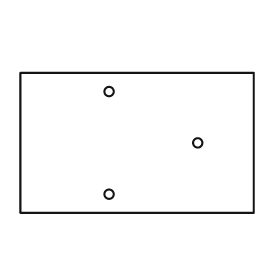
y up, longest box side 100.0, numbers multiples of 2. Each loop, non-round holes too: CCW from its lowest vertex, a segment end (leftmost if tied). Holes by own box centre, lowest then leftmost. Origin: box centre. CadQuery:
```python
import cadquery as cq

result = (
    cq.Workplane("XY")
    .moveTo(-50.0, -30.0)
    .lineTo(50.0, -30.0)
    .lineTo(50.0, 30.0)
    .lineTo(-50.0, 30.0)
    .close()
    .moveTo(-12.0, -22.0)
    .circle(2.0)
    .moveTo(26.0, 0.0)
    .circle(2.0)
    .moveTo(-12.0, 22.0)
    .circle(2.0)
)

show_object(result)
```